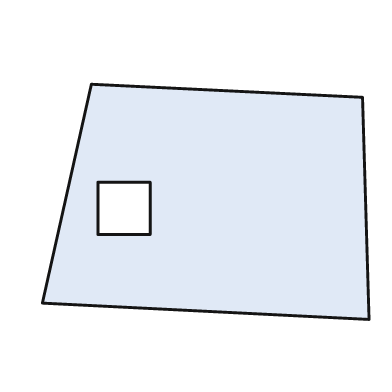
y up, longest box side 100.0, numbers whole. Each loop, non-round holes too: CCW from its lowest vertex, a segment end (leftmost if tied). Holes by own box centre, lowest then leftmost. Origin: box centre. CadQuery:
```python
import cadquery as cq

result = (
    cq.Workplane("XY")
    .moveTo(50.0, -36.0)
    .lineTo(48.0, 32.0)
    .lineTo(-35.0, 36.0)
    .lineTo(-50.0, -31.0)
    .close()
    .moveTo(-33.0, -10.0)
    .lineTo(-17.0, -10.0)
    .lineTo(-17.0, 6.0)
    .lineTo(-33.0, 6.0)
    .close()
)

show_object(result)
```